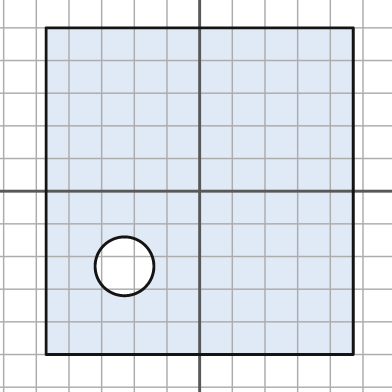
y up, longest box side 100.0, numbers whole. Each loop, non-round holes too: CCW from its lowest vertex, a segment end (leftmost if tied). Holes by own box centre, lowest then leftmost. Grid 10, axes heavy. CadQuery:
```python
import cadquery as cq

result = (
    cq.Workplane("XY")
    .moveTo(-47.0, -50.0)
    .lineTo(47.0, -50.0)
    .lineTo(47.0, 50.0)
    .lineTo(-47.0, 50.0)
    .close()
    .moveTo(-23.0, -23.0)
    .circle(9.0)
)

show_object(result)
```